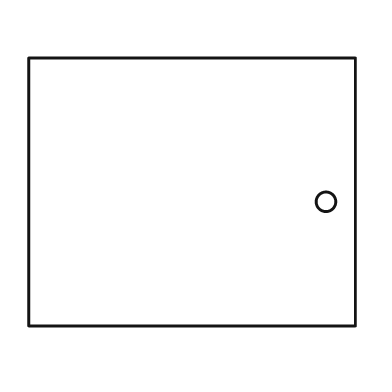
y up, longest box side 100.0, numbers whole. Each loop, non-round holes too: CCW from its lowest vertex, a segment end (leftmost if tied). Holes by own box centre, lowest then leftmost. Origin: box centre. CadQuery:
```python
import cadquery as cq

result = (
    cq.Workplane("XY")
    .moveTo(-50.0, -41.0)
    .lineTo(50.0, -41.0)
    .lineTo(50.0, 41.0)
    .lineTo(-50.0, 41.0)
    .close()
    .moveTo(41.0, -3.0)
    .circle(3.0)
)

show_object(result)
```